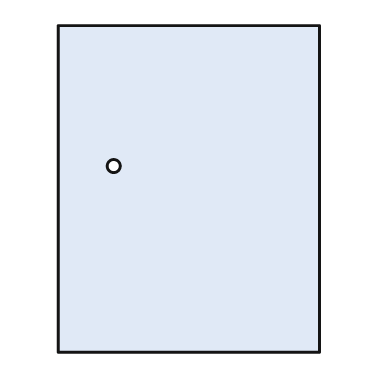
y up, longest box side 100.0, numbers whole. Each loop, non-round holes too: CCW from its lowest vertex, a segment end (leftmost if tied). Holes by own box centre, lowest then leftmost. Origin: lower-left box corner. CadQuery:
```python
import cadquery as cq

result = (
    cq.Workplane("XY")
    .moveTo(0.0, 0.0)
    .lineTo(80.0, 0.0)
    .lineTo(80.0, 100.0)
    .lineTo(0.0, 100.0)
    .close()
    .moveTo(17.0, 57.0)
    .circle(2.0)
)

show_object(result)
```